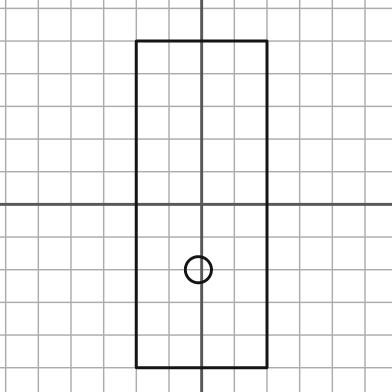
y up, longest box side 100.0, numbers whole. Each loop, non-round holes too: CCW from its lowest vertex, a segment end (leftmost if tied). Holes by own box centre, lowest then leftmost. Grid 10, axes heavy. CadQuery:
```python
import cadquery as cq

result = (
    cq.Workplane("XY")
    .moveTo(-20.0, -50.0)
    .lineTo(20.0, -50.0)
    .lineTo(20.0, 50.0)
    .lineTo(-20.0, 50.0)
    .close()
    .moveTo(-1.0, -20.0)
    .circle(4.0)
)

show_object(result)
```